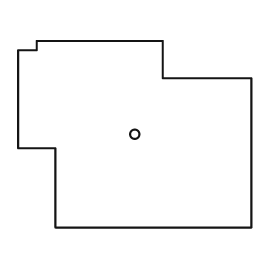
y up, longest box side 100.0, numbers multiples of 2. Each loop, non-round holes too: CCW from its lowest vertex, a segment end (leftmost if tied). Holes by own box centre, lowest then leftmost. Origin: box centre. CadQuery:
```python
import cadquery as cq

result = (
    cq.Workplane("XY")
    .moveTo(-34.0, -40.0)
    .lineTo(50.0, -40.0)
    .lineTo(50.0, 24.0)
    .lineTo(12.0, 24.0)
    .lineTo(12.0, 40.0)
    .lineTo(-42.0, 40.0)
    .lineTo(-42.0, 36.0)
    .lineTo(-50.0, 36.0)
    .lineTo(-50.0, -6.0)
    .lineTo(-34.0, -6.0)
    .close()
    .moveTo(0.0, 0.0)
    .circle(2.0)
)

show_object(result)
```